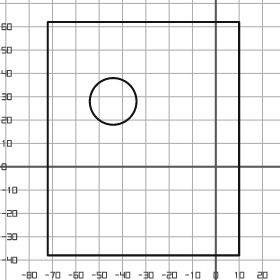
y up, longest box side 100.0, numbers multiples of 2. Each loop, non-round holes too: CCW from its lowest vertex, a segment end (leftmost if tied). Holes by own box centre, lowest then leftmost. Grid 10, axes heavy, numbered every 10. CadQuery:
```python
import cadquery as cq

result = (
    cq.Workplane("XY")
    .moveTo(-72.0, -38.0)
    .lineTo(10.0, -38.0)
    .lineTo(10.0, 62.0)
    .lineTo(-72.0, 62.0)
    .close()
    .moveTo(-44.0, 28.0)
    .circle(10.0)
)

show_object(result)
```